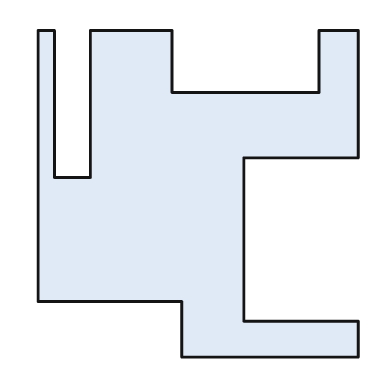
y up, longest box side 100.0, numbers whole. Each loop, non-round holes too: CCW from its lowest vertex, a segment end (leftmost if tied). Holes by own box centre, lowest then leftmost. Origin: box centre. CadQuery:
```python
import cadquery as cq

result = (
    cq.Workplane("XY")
    .moveTo(-5.0, -50.0)
    .lineTo(49.0, -50.0)
    .lineTo(49.0, -39.0)
    .lineTo(14.0, -39.0)
    .lineTo(14.0, 11.0)
    .lineTo(49.0, 11.0)
    .lineTo(49.0, 50.0)
    .lineTo(37.0, 50.0)
    .lineTo(37.0, 31.0)
    .lineTo(-8.0, 31.0)
    .lineTo(-8.0, 50.0)
    .lineTo(-33.0, 50.0)
    .lineTo(-33.0, 5.0)
    .lineTo(-44.0, 5.0)
    .lineTo(-44.0, 50.0)
    .lineTo(-49.0, 50.0)
    .lineTo(-49.0, -33.0)
    .lineTo(-5.0, -33.0)
    .close()
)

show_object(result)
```